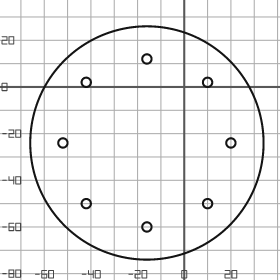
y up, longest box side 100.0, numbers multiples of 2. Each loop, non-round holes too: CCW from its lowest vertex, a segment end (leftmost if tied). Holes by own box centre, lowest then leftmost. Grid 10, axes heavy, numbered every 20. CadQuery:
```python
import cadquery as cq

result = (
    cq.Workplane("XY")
    .moveTo(-16.0, -24.0)
    .circle(50.0)
    .moveTo(-16.0, -60.0)
    .circle(2.0)
    .moveTo(-42.0, -50.0)
    .circle(2.0)
    .moveTo(10.0, -50.0)
    .circle(2.0)
    .moveTo(-52.0, -24.0)
    .circle(2.0)
    .moveTo(20.0, -24.0)
    .circle(2.0)
    .moveTo(-42.0, 2.0)
    .circle(2.0)
    .moveTo(10.0, 2.0)
    .circle(2.0)
    .moveTo(-16.0, 12.0)
    .circle(2.0)
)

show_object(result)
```